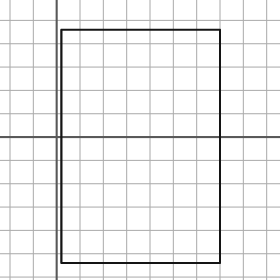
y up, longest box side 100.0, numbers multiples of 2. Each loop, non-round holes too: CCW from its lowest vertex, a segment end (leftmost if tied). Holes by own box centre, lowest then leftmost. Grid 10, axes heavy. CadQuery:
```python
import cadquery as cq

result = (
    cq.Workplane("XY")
    .moveTo(2.0, -54.0)
    .lineTo(70.0, -54.0)
    .lineTo(70.0, 46.0)
    .lineTo(2.0, 46.0)
    .close()
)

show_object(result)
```